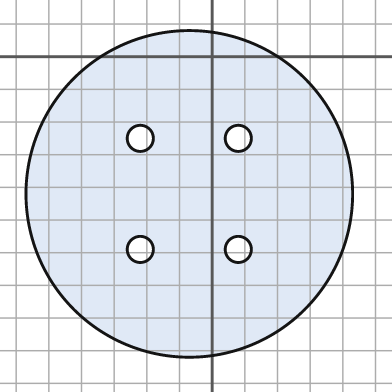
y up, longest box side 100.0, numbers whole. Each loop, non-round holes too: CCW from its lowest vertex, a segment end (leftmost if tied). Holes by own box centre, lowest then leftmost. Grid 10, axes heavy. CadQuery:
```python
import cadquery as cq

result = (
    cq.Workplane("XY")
    .moveTo(-7.0, -42.0)
    .circle(50.0)
    .moveTo(-22.0, -59.0)
    .circle(4.0)
    .moveTo(8.0, -59.0)
    .circle(4.0)
    .moveTo(-22.0, -25.0)
    .circle(4.0)
    .moveTo(8.0, -25.0)
    .circle(4.0)
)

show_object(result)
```